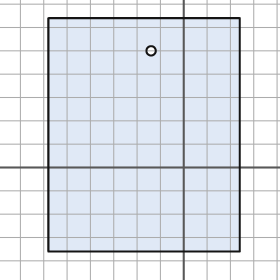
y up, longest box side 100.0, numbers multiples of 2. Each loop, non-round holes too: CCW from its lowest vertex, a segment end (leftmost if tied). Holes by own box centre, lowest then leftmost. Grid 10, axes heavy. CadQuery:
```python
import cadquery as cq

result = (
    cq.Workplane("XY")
    .moveTo(-58.0, -36.0)
    .lineTo(24.0, -36.0)
    .lineTo(24.0, 64.0)
    .lineTo(-58.0, 64.0)
    .close()
    .moveTo(-14.0, 50.0)
    .circle(2.0)
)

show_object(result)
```